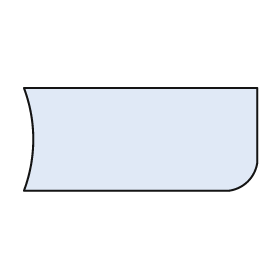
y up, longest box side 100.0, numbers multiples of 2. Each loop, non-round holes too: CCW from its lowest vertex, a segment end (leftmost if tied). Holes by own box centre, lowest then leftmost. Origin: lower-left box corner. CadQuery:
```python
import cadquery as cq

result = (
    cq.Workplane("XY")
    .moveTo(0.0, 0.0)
    .lineTo(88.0, 0.0)
    .threePointArc((96.0, 4.0), (100.0, 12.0))
    .lineTo(100.0, 44.0)
    .lineTo(0.0, 44.0)
    .threePointArc((4.0, 22.0), (0.0, 0.0))
    .close()
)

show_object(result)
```